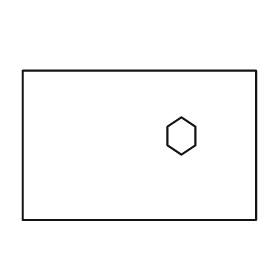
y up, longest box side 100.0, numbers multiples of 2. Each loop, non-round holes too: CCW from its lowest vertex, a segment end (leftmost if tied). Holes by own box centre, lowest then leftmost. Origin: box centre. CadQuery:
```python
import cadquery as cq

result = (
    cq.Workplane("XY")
    .moveTo(-50.0, -32.0)
    .lineTo(50.0, -32.0)
    .lineTo(50.0, 32.0)
    .lineTo(-50.0, 32.0)
    .close()
    .moveTo(18.0, -4.0)
    .lineTo(24.0, 0.0)
    .lineTo(24.0, 8.0)
    .lineTo(18.0, 12.0)
    .lineTo(12.0, 8.0)
    .lineTo(12.0, 0.0)
    .close()
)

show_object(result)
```